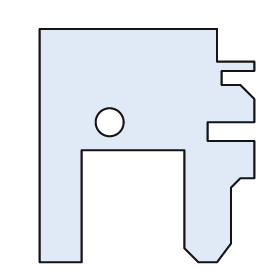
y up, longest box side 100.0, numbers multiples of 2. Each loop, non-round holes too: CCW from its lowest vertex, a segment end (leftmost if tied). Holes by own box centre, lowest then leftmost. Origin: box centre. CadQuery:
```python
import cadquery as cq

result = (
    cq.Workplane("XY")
    .moveTo(-46.0, -50.0)
    .lineTo(-28.0, -50.0)
    .lineTo(-28.0, -2.0)
    .lineTo(16.0, -2.0)
    .lineTo(16.0, -44.0)
    .lineTo(22.0, -50.0)
    .lineTo(30.0, -50.0)
    .lineTo(36.0, -42.0)
    .lineTo(36.0, -18.0)
    .lineTo(40.0, -14.0)
    .lineTo(46.0, -14.0)
    .lineTo(46.0, 2.0)
    .lineTo(26.0, 2.0)
    .lineTo(26.0, 10.0)
    .lineTo(46.0, 10.0)
    .lineTo(46.0, 20.0)
    .lineTo(40.0, 26.0)
    .lineTo(32.0, 26.0)
    .lineTo(32.0, 32.0)
    .lineTo(46.0, 32.0)
    .lineTo(46.0, 36.0)
    .lineTo(30.0, 36.0)
    .lineTo(30.0, 50.0)
    .lineTo(-46.0, 50.0)
    .close()
    .moveTo(-16.0, 10.0)
    .circle(6.0)
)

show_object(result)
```